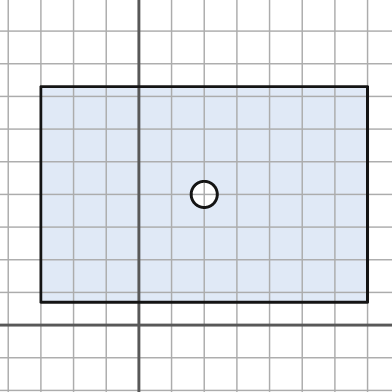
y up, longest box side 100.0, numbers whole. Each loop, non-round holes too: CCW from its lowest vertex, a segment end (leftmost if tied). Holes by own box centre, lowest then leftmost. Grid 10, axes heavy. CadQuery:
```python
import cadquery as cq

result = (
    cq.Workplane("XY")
    .moveTo(-30.0, 7.0)
    .lineTo(70.0, 7.0)
    .lineTo(70.0, 73.0)
    .lineTo(-30.0, 73.0)
    .close()
    .moveTo(20.0, 40.0)
    .circle(4.0)
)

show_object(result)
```